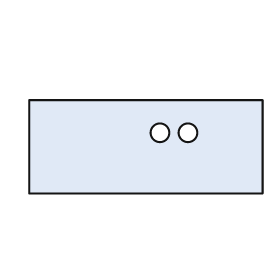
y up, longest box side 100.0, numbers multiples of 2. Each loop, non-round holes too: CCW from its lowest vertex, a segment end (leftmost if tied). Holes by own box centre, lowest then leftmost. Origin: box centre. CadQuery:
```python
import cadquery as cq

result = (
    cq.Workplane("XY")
    .moveTo(-50.0, -20.0)
    .lineTo(50.0, -20.0)
    .lineTo(50.0, 20.0)
    .lineTo(-50.0, 20.0)
    .close()
    .moveTo(6.0, 6.0)
    .circle(4.0)
    .moveTo(18.0, 6.0)
    .circle(4.0)
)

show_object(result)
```